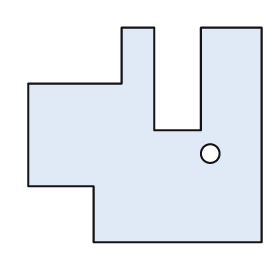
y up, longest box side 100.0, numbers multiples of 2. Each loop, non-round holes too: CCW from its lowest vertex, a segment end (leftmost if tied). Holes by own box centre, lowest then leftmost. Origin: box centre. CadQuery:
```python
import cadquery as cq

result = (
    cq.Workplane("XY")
    .moveTo(-22.0, -46.0)
    .lineTo(50.0, -46.0)
    .lineTo(50.0, 46.0)
    .lineTo(24.0, 46.0)
    .lineTo(24.0, 2.0)
    .lineTo(4.0, 2.0)
    .lineTo(4.0, 46.0)
    .lineTo(-10.0, 46.0)
    .lineTo(-10.0, 22.0)
    .lineTo(-50.0, 22.0)
    .lineTo(-50.0, -22.0)
    .lineTo(-22.0, -22.0)
    .close()
    .moveTo(28.0, -8.0)
    .circle(4.0)
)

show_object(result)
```